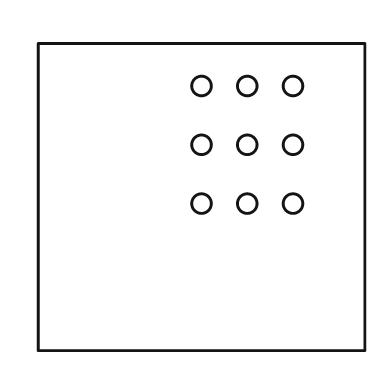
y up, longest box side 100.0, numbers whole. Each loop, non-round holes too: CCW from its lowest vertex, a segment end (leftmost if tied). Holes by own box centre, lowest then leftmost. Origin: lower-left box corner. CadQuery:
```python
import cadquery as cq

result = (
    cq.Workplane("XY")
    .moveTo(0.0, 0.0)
    .lineTo(100.0, 0.0)
    .lineTo(100.0, 94.0)
    .lineTo(0.0, 94.0)
    .close()
    .moveTo(50.0, 45.0)
    .circle(3.0)
    .moveTo(64.0, 45.0)
    .circle(3.0)
    .moveTo(78.0, 45.0)
    .circle(3.0)
    .moveTo(50.0, 63.0)
    .circle(3.0)
    .moveTo(64.0, 63.0)
    .circle(3.0)
    .moveTo(78.0, 63.0)
    .circle(3.0)
    .moveTo(50.0, 81.0)
    .circle(3.0)
    .moveTo(64.0, 81.0)
    .circle(3.0)
    .moveTo(78.0, 81.0)
    .circle(3.0)
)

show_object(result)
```